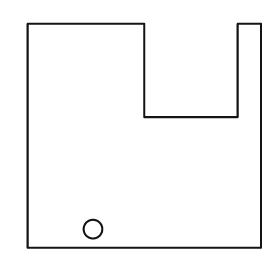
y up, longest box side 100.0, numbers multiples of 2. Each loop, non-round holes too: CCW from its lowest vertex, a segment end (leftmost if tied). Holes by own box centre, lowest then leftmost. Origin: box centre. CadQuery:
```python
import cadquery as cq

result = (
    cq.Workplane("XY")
    .moveTo(-50.0, -48.0)
    .lineTo(50.0, -48.0)
    .lineTo(50.0, 48.0)
    .lineTo(40.0, 48.0)
    .lineTo(40.0, 8.0)
    .lineTo(0.0, 8.0)
    .lineTo(0.0, 48.0)
    .lineTo(-50.0, 48.0)
    .close()
    .moveTo(-22.0, -40.0)
    .circle(4.0)
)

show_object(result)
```